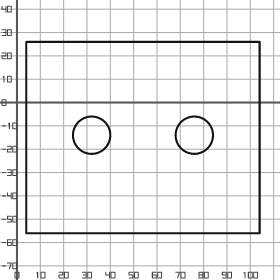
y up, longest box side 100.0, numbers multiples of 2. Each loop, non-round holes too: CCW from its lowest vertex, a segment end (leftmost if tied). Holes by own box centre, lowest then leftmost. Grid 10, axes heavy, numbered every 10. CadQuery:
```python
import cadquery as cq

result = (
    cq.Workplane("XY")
    .moveTo(4.0, -56.0)
    .lineTo(104.0, -56.0)
    .lineTo(104.0, 26.0)
    .lineTo(4.0, 26.0)
    .close()
    .moveTo(32.0, -14.0)
    .circle(8.0)
    .moveTo(76.0, -14.0)
    .circle(8.0)
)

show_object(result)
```